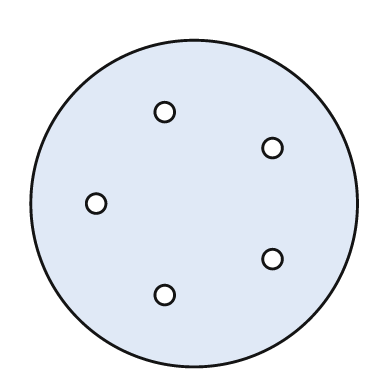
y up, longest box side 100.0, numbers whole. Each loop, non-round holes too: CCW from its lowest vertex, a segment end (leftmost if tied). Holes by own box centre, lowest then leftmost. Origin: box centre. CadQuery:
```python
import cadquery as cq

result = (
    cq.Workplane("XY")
    .moveTo(0.0, 0.0)
    .circle(50.0)
    .moveTo(-9.0, -28.0)
    .circle(3.0)
    .moveTo(24.0, -17.0)
    .circle(3.0)
    .moveTo(-30.0, 0.0)
    .circle(3.0)
    .moveTo(24.0, 17.0)
    .circle(3.0)
    .moveTo(-9.0, 28.0)
    .circle(3.0)
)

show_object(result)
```